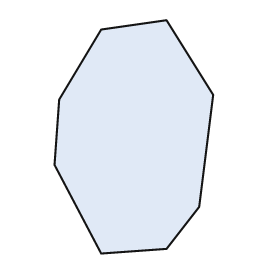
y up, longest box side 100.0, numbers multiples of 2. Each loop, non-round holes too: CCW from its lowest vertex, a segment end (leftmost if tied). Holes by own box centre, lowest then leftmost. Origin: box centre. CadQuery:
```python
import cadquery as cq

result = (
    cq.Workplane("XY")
    .moveTo(-14.0, -50.0)
    .lineTo(14.0, -48.0)
    .lineTo(28.0, -30.0)
    .lineTo(34.0, 18.0)
    .lineTo(14.0, 50.0)
    .lineTo(-14.0, 46.0)
    .lineTo(-32.0, 16.0)
    .lineTo(-34.0, -12.0)
    .close()
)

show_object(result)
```